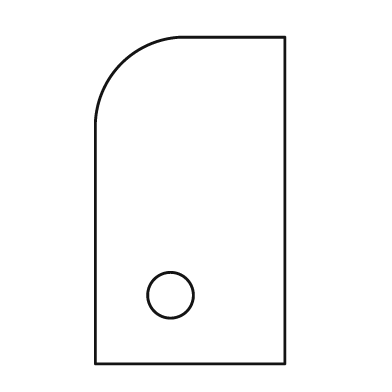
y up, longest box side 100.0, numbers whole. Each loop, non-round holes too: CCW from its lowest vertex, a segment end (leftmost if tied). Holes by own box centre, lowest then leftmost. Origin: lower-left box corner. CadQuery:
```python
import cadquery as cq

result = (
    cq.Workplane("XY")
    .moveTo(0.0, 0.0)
    .lineTo(58.0, 0.0)
    .lineTo(58.0, 100.0)
    .lineTo(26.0, 100.0)
    .threePointArc((8.0, 92.0), (0.0, 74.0))
    .close()
    .moveTo(23.0, 21.0)
    .circle(7.0)
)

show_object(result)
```